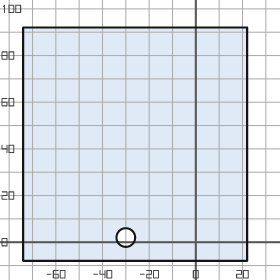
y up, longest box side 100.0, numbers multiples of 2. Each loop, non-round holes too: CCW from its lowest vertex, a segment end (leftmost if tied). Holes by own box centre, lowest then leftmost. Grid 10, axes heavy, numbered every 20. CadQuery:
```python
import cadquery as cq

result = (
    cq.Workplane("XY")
    .moveTo(-74.0, -8.0)
    .lineTo(22.0, -8.0)
    .lineTo(22.0, 92.0)
    .lineTo(-74.0, 92.0)
    .close()
    .moveTo(-30.0, 2.0)
    .circle(4.0)
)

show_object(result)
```